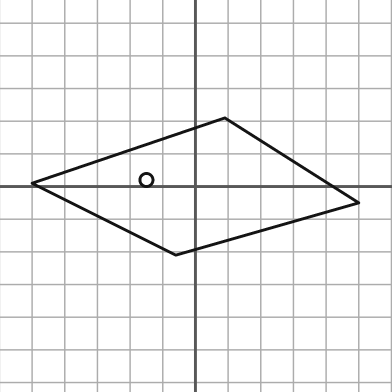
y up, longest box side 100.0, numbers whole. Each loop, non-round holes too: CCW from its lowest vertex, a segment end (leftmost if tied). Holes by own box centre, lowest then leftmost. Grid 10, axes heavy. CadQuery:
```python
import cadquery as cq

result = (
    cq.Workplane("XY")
    .moveTo(-6.0, -21.0)
    .lineTo(50.0, -5.0)
    .lineTo(9.0, 21.0)
    .lineTo(-50.0, 1.0)
    .close()
    .moveTo(-15.0, 2.0)
    .circle(2.0)
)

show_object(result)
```